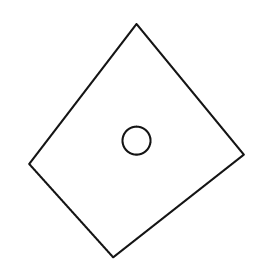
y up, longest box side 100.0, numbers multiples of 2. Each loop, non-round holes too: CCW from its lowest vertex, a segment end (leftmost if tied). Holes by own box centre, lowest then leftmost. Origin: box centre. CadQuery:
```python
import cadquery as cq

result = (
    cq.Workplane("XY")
    .moveTo(-10.0, -50.0)
    .lineTo(46.0, -6.0)
    .lineTo(0.0, 50.0)
    .lineTo(-46.0, -10.0)
    .close()
    .moveTo(0.0, 0.0)
    .circle(6.0)
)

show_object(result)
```